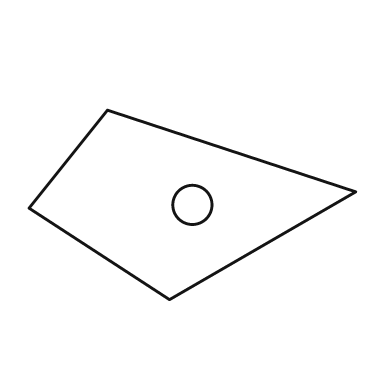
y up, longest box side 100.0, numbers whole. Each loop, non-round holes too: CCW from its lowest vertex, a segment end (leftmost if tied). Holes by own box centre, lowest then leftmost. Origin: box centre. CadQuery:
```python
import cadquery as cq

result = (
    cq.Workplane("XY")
    .moveTo(-7.0, -29.0)
    .lineTo(50.0, 4.0)
    .lineTo(-26.0, 29.0)
    .lineTo(-50.0, -1.0)
    .close()
    .moveTo(0.0, 0.0)
    .circle(6.0)
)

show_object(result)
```